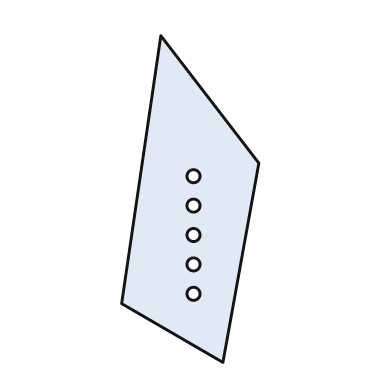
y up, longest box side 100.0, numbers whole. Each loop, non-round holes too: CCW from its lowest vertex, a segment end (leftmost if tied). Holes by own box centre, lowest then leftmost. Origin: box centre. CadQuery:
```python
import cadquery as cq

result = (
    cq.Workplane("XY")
    .moveTo(10.0, -50.0)
    .lineTo(21.0, 11.0)
    .lineTo(-9.0, 50.0)
    .lineTo(-21.0, -32.0)
    .close()
    .moveTo(1.0, -29.0)
    .circle(2.0)
    .moveTo(1.0, -20.0)
    .circle(2.0)
    .moveTo(1.0, -11.0)
    .circle(2.0)
    .moveTo(1.0, -2.0)
    .circle(2.0)
    .moveTo(1.0, 7.0)
    .circle(2.0)
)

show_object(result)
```